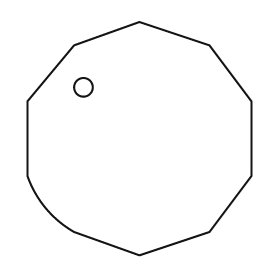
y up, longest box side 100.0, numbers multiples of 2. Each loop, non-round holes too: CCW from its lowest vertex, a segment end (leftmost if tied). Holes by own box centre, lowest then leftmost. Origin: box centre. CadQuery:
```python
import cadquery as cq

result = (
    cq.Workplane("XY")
    .moveTo(0.0, -50.0)
    .lineTo(30.0, -40.0)
    .lineTo(48.0, -16.0)
    .lineTo(48.0, 16.0)
    .lineTo(30.0, 40.0)
    .lineTo(0.0, 50.0)
    .lineTo(-28.0, 40.0)
    .lineTo(-48.0, 16.0)
    .lineTo(-48.0, -16.0)
    .threePointArc((-40.0, -30.0), (-28.0, -40.0))
    .close()
    .moveTo(-24.0, 22.0)
    .circle(4.0)
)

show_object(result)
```